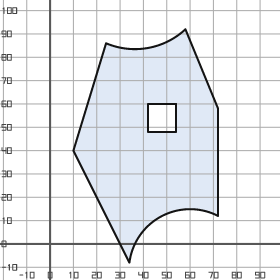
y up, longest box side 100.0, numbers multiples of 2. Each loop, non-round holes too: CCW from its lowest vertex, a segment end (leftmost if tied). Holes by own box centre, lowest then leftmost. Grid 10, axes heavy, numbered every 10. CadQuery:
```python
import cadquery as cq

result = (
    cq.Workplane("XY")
    .moveTo(34.0, -8.0)
    .threePointArc((48.0, 12.0), (72.0, 12.0))
    .lineTo(72.0, 58.0)
    .lineTo(58.0, 92.0)
    .threePointArc((42.0, 84.0), (24.0, 86.0))
    .lineTo(10.0, 40.0)
    .close()
    .moveTo(42.0, 48.0)
    .lineTo(54.0, 48.0)
    .lineTo(54.0, 60.0)
    .lineTo(42.0, 60.0)
    .close()
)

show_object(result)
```